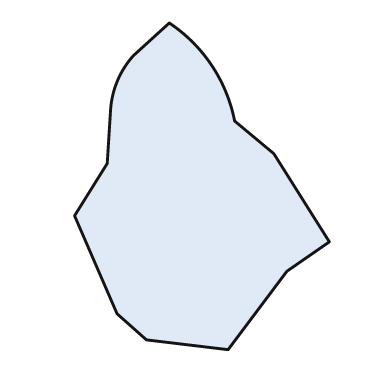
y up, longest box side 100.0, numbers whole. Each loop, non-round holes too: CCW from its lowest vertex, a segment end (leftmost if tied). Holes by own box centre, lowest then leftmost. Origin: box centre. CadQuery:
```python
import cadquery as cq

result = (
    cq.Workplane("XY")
    .moveTo(8.0, -50.0)
    .lineTo(26.0, -26.0)
    .lineTo(39.0, -17.0)
    .lineTo(22.0, 10.0)
    .lineTo(10.0, 20.0)
    .threePointArc((3.0, 37.0), (-10.0, 50.0))
    .lineTo(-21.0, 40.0)
    .threePointArc((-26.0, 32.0), (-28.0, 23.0))
    .lineTo(-29.0, 7.0)
    .lineTo(-39.0, -9.0)
    .lineTo(-26.0, -39.0)
    .lineTo(-17.0, -47.0)
    .close()
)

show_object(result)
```